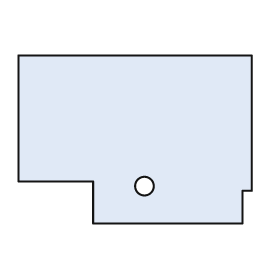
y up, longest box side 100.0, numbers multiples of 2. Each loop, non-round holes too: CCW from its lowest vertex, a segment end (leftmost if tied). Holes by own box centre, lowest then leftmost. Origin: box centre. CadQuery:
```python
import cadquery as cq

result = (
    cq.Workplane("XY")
    .moveTo(-18.0, -36.0)
    .lineTo(46.0, -36.0)
    .lineTo(46.0, -22.0)
    .lineTo(50.0, -22.0)
    .lineTo(50.0, 36.0)
    .lineTo(-50.0, 36.0)
    .lineTo(-50.0, -18.0)
    .lineTo(-18.0, -18.0)
    .close()
    .moveTo(4.0, -20.0)
    .circle(4.0)
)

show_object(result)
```